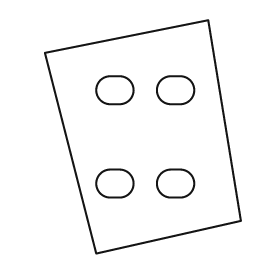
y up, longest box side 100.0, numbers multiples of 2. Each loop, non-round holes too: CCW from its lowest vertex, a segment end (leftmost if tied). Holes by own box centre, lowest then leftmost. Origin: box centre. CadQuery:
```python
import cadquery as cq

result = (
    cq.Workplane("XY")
    .moveTo(-20.0, -50.0)
    .lineTo(42.0, -36.0)
    .lineTo(28.0, 50.0)
    .lineTo(-42.0, 36.0)
    .close()
    .moveTo(-14.0, -26.0)
    .lineTo(-10.0, -26.0)
    .threePointArc((-4.0, -20.0), (-10.0, -14.0))
    .lineTo(-14.0, -14.0)
    .threePointArc((-20.0, -20.0), (-14.0, -26.0))
    .close()
    .moveTo(12.0, -26.0)
    .lineTo(16.0, -26.0)
    .threePointArc((22.0, -20.0), (16.0, -14.0))
    .lineTo(12.0, -14.0)
    .threePointArc((6.0, -20.0), (12.0, -26.0))
    .close()
    .moveTo(-14.0, 14.0)
    .lineTo(-10.0, 14.0)
    .threePointArc((-4.0, 20.0), (-10.0, 26.0))
    .lineTo(-14.0, 26.0)
    .threePointArc((-20.0, 20.0), (-14.0, 14.0))
    .close()
    .moveTo(12.0, 14.0)
    .lineTo(16.0, 14.0)
    .threePointArc((22.0, 20.0), (16.0, 26.0))
    .lineTo(12.0, 26.0)
    .threePointArc((6.0, 20.0), (12.0, 14.0))
    .close()
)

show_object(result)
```